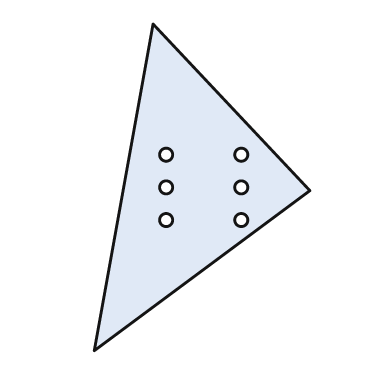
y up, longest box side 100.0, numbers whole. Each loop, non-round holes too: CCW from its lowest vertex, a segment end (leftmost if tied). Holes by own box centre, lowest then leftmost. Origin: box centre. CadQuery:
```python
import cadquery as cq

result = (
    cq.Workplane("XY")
    .moveTo(-33.0, -50.0)
    .lineTo(33.0, -1.0)
    .lineTo(-15.0, 50.0)
    .close()
    .moveTo(-11.0, -10.0)
    .circle(2.0)
    .moveTo(12.0, -10.0)
    .circle(2.0)
    .moveTo(-11.0, 0.0)
    .circle(2.0)
    .moveTo(12.0, 0.0)
    .circle(2.0)
    .moveTo(-11.0, 10.0)
    .circle(2.0)
    .moveTo(12.0, 10.0)
    .circle(2.0)
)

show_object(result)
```